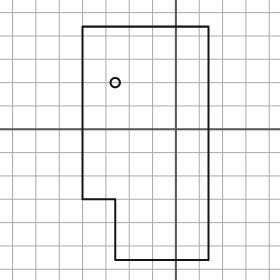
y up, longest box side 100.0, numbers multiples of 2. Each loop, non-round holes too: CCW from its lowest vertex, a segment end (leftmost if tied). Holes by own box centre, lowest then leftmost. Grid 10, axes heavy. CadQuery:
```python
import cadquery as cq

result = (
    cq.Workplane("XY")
    .moveTo(-26.0, -56.0)
    .lineTo(14.0, -56.0)
    .lineTo(14.0, 44.0)
    .lineTo(-40.0, 44.0)
    .lineTo(-40.0, -30.0)
    .lineTo(-26.0, -30.0)
    .close()
    .moveTo(-26.0, 20.0)
    .circle(2.0)
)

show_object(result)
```